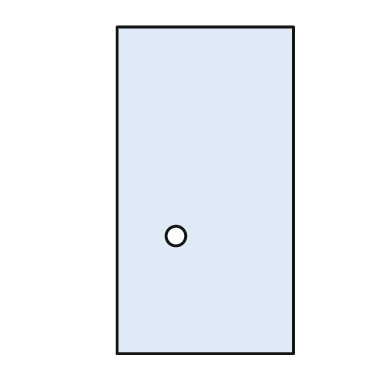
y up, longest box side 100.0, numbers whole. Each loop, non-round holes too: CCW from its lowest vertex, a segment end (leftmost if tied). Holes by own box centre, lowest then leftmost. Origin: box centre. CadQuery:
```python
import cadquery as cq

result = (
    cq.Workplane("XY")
    .moveTo(-27.0, -50.0)
    .lineTo(27.0, -50.0)
    .lineTo(27.0, 50.0)
    .lineTo(-27.0, 50.0)
    .close()
    .moveTo(-9.0, -14.0)
    .circle(3.0)
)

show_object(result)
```